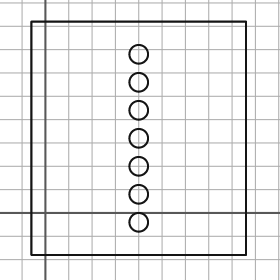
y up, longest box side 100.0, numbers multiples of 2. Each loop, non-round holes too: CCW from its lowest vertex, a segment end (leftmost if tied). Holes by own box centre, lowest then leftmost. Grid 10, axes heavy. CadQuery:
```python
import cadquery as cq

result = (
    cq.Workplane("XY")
    .moveTo(-6.0, -18.0)
    .lineTo(86.0, -18.0)
    .lineTo(86.0, 82.0)
    .lineTo(-6.0, 82.0)
    .close()
    .moveTo(40.0, -4.0)
    .circle(4.0)
    .moveTo(40.0, 8.0)
    .circle(4.0)
    .moveTo(40.0, 20.0)
    .circle(4.0)
    .moveTo(40.0, 32.0)
    .circle(4.0)
    .moveTo(40.0, 44.0)
    .circle(4.0)
    .moveTo(40.0, 56.0)
    .circle(4.0)
    .moveTo(40.0, 68.0)
    .circle(4.0)
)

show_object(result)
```